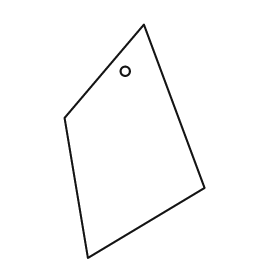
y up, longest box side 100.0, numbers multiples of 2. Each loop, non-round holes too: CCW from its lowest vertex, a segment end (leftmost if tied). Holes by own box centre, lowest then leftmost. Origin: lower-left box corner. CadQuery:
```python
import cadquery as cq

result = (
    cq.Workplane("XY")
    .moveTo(10.0, 0.0)
    .lineTo(60.0, 30.0)
    .lineTo(34.0, 100.0)
    .lineTo(0.0, 60.0)
    .close()
    .moveTo(26.0, 80.0)
    .circle(2.0)
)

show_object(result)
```